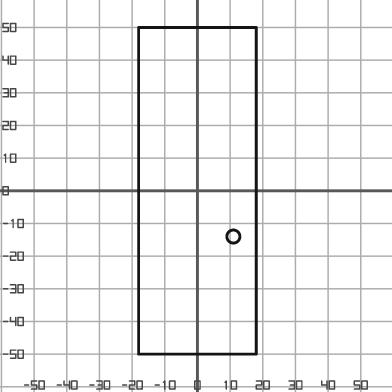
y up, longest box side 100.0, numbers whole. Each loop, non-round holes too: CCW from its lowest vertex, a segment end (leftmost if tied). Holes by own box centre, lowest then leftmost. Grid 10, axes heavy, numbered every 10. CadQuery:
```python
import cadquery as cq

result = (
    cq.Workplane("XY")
    .moveTo(-18.0, -50.0)
    .lineTo(18.0, -50.0)
    .lineTo(18.0, 50.0)
    .lineTo(-18.0, 50.0)
    .close()
    .moveTo(11.0, -14.0)
    .circle(2.0)
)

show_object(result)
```